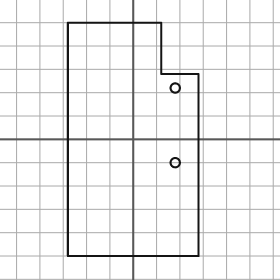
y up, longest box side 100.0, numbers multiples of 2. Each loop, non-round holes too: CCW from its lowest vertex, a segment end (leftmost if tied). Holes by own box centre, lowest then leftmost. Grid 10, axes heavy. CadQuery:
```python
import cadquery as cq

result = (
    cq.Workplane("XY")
    .moveTo(-28.0, -50.0)
    .lineTo(28.0, -50.0)
    .lineTo(28.0, 28.0)
    .lineTo(12.0, 28.0)
    .lineTo(12.0, 50.0)
    .lineTo(-28.0, 50.0)
    .close()
    .moveTo(18.0, -10.0)
    .circle(2.0)
    .moveTo(18.0, 22.0)
    .circle(2.0)
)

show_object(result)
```